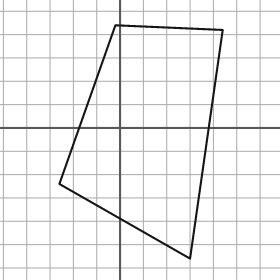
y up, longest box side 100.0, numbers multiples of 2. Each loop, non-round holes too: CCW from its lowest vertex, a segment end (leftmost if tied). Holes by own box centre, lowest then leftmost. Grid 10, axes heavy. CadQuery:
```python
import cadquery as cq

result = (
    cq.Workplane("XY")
    .moveTo(30.0, -56.0)
    .lineTo(44.0, 42.0)
    .lineTo(-2.0, 44.0)
    .lineTo(-26.0, -24.0)
    .close()
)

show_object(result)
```